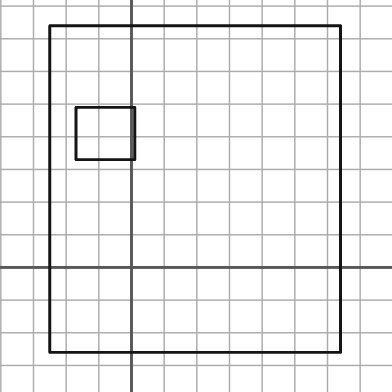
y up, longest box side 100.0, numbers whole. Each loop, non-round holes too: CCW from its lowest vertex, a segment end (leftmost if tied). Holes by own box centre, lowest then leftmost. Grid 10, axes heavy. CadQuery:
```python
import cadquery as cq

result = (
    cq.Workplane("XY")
    .moveTo(-25.0, -26.0)
    .lineTo(64.0, -26.0)
    .lineTo(64.0, 74.0)
    .lineTo(-25.0, 74.0)
    .close()
    .moveTo(-17.0, 33.0)
    .lineTo(1.0, 33.0)
    .lineTo(1.0, 49.0)
    .lineTo(-17.0, 49.0)
    .close()
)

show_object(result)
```